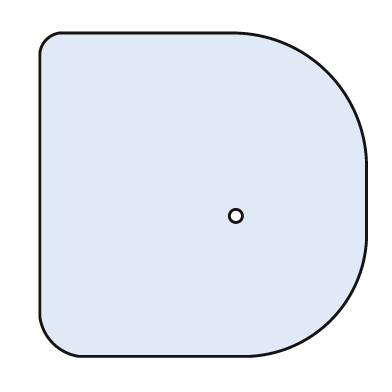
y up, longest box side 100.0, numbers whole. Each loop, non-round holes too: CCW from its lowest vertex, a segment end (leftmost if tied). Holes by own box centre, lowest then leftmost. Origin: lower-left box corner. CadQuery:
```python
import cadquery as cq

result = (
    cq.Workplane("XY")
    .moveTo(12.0, 0.0)
    .lineTo(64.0, 0.0)
    .threePointArc((89.0, 11.0), (100.0, 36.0))
    .lineTo(100.0, 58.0)
    .threePointArc((88.0, 87.0), (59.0, 99.0))
    .lineTo(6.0, 99.0)
    .threePointArc((2.0, 97.0), (0.0, 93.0))
    .lineTo(0.0, 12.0)
    .threePointArc((4.0, 4.0), (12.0, 0.0))
    .close()
    .moveTo(60.0, 43.0)
    .circle(2.0)
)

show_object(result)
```